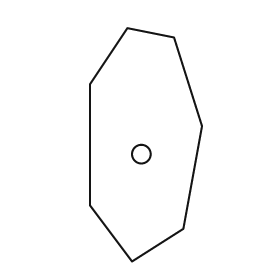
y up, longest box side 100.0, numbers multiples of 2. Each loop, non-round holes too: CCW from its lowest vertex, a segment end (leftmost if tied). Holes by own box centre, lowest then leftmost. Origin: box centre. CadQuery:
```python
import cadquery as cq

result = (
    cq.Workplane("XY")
    .moveTo(-6.0, -50.0)
    .lineTo(16.0, -36.0)
    .lineTo(24.0, 8.0)
    .lineTo(12.0, 46.0)
    .lineTo(-8.0, 50.0)
    .lineTo(-24.0, 26.0)
    .lineTo(-24.0, -26.0)
    .close()
    .moveTo(-2.0, -4.0)
    .circle(4.0)
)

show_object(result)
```